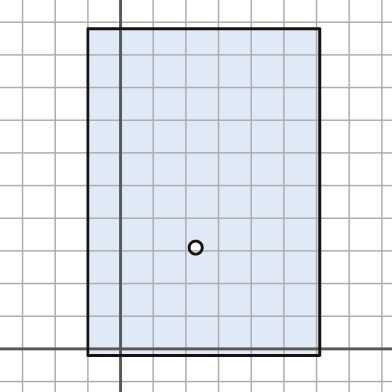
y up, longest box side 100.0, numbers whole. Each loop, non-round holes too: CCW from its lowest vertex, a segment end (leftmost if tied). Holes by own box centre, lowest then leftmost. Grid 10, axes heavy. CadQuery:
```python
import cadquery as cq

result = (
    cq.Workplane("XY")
    .moveTo(-10.0, -2.0)
    .lineTo(61.0, -2.0)
    .lineTo(61.0, 98.0)
    .lineTo(-10.0, 98.0)
    .close()
    .moveTo(23.0, 31.0)
    .circle(2.0)
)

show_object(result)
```